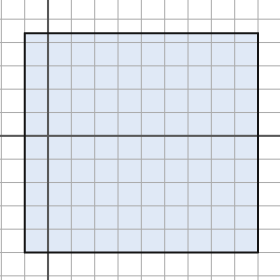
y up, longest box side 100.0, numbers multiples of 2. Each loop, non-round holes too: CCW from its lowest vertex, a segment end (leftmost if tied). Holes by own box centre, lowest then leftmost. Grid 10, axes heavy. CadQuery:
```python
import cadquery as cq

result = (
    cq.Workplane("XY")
    .moveTo(-10.0, -50.0)
    .lineTo(90.0, -50.0)
    .lineTo(90.0, 44.0)
    .lineTo(-10.0, 44.0)
    .close()
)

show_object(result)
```